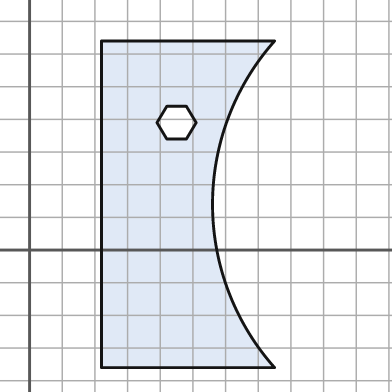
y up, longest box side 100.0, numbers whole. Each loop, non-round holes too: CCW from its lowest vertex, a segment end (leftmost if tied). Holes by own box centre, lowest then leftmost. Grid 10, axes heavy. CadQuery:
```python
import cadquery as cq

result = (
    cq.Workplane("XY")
    .moveTo(22.0, -36.0)
    .lineTo(75.0, -36.0)
    .threePointArc((56.0, 14.0), (75.0, 64.0))
    .lineTo(22.0, 64.0)
    .close()
    .moveTo(42.0, 34.0)
    .lineTo(48.0, 34.0)
    .lineTo(51.0, 39.0)
    .lineTo(48.0, 44.0)
    .lineTo(42.0, 44.0)
    .lineTo(39.0, 39.0)
    .close()
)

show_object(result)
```